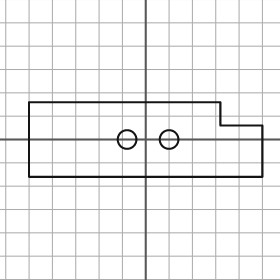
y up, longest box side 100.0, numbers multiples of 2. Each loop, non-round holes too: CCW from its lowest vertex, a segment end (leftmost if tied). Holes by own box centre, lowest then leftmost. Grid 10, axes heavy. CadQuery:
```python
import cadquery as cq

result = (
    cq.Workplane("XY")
    .moveTo(-50.0, -16.0)
    .lineTo(50.0, -16.0)
    .lineTo(50.0, 6.0)
    .lineTo(32.0, 6.0)
    .lineTo(32.0, 16.0)
    .lineTo(-50.0, 16.0)
    .close()
    .moveTo(-8.0, 0.0)
    .circle(4.0)
    .moveTo(10.0, 0.0)
    .circle(4.0)
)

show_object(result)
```